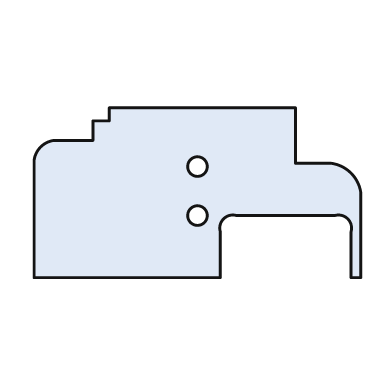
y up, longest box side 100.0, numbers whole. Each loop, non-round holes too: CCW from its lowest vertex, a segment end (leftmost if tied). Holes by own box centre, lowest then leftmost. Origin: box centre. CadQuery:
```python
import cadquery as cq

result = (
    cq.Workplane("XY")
    .moveTo(-50.0, -26.0)
    .lineTo(7.0, -26.0)
    .lineTo(7.0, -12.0)
    .threePointArc((8.0, -8.0), (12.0, -7.0))
    .lineTo(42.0, -7.0)
    .threePointArc((46.0, -8.0), (47.0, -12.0))
    .lineTo(47.0, -26.0)
    .lineTo(50.0, -26.0)
    .lineTo(50.0, 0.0)
    .threePointArc((47.0, 6.0), (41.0, 9.0))
    .lineTo(30.0, 9.0)
    .lineTo(30.0, 26.0)
    .lineTo(-27.0, 26.0)
    .lineTo(-27.0, 22.0)
    .lineTo(-32.0, 22.0)
    .lineTo(-32.0, 16.0)
    .lineTo(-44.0, 16.0)
    .threePointArc((-48.0, 14.0), (-50.0, 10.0))
    .close()
    .moveTo(0.0, -7.0)
    .circle(3.0)
    .moveTo(0.0, 8.0)
    .circle(3.0)
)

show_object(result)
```